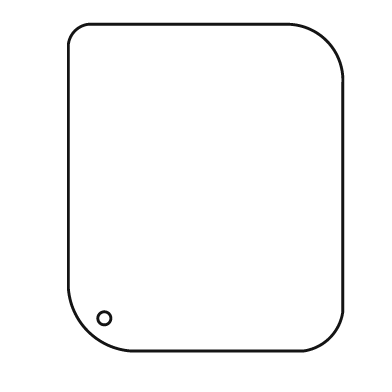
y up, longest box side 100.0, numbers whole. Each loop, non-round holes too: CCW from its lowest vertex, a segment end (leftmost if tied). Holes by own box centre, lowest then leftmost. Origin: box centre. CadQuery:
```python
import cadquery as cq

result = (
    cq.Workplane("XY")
    .moveTo(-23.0, -50.0)
    .lineTo(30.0, -50.0)
    .threePointArc((38.0, -46.0), (42.0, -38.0))
    .lineTo(42.0, 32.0)
    .threePointArc((37.0, 45.0), (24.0, 50.0))
    .lineTo(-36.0, 50.0)
    .threePointArc((-40.0, 48.0), (-42.0, 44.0))
    .lineTo(-42.0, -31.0)
    .threePointArc((-36.0, -44.0), (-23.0, -50.0))
    .close()
    .moveTo(-31.0, -40.0)
    .circle(2.0)
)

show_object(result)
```